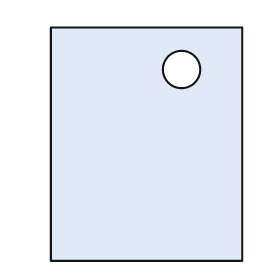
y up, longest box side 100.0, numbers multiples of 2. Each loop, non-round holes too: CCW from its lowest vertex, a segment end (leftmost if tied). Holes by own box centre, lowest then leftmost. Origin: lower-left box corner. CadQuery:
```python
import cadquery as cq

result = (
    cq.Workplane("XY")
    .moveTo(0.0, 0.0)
    .lineTo(82.0, 0.0)
    .lineTo(82.0, 100.0)
    .lineTo(0.0, 100.0)
    .close()
    .moveTo(56.0, 82.0)
    .circle(8.0)
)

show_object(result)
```